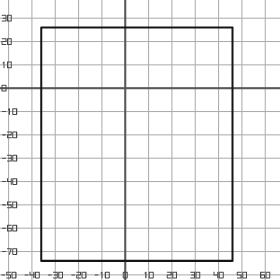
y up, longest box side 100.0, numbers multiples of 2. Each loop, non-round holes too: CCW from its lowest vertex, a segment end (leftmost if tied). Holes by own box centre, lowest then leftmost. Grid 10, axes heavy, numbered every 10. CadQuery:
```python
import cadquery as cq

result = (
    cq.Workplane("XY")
    .moveTo(-36.0, -74.0)
    .lineTo(46.0, -74.0)
    .lineTo(46.0, 26.0)
    .lineTo(-36.0, 26.0)
    .close()
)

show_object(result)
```